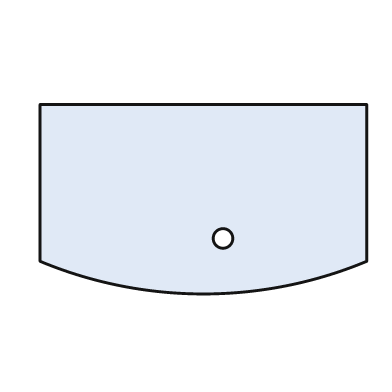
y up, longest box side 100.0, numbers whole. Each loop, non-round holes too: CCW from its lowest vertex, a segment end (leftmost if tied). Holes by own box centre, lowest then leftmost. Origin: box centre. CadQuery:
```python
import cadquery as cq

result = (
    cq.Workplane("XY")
    .moveTo(-50.0, -19.0)
    .threePointArc((0.0, -29.0), (50.0, -19.0))
    .lineTo(50.0, 29.0)
    .lineTo(-50.0, 29.0)
    .close()
    .moveTo(6.0, -12.0)
    .circle(3.0)
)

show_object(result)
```